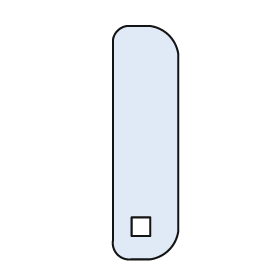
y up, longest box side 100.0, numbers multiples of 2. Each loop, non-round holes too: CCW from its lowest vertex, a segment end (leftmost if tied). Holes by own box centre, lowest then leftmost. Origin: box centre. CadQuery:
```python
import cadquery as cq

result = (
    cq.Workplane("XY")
    .moveTo(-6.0, -50.0)
    .lineTo(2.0, -50.0)
    .threePointArc((10.0, -46.0), (14.0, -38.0))
    .lineTo(14.0, 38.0)
    .threePointArc((10.0, 46.0), (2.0, 50.0))
    .lineTo(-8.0, 50.0)
    .threePointArc((-12.0, 48.0), (-14.0, 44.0))
    .lineTo(-14.0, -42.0)
    .threePointArc((-12.0, -48.0), (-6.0, -50.0))
    .close()
    .moveTo(-6.0, -40.0)
    .lineTo(2.0, -40.0)
    .lineTo(2.0, -32.0)
    .lineTo(-6.0, -32.0)
    .close()
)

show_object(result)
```